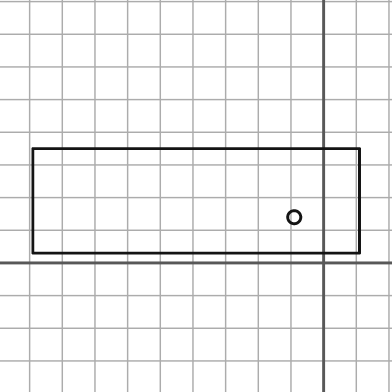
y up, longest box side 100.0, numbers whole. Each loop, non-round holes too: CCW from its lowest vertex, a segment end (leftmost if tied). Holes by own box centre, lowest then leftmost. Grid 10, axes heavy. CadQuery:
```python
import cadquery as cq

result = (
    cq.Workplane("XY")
    .moveTo(-89.0, 3.0)
    .lineTo(11.0, 3.0)
    .lineTo(11.0, 35.0)
    .lineTo(-89.0, 35.0)
    .close()
    .moveTo(-9.0, 14.0)
    .circle(2.0)
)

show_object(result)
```